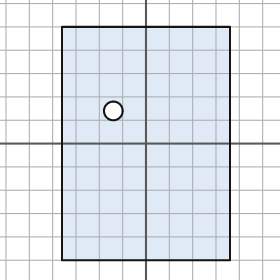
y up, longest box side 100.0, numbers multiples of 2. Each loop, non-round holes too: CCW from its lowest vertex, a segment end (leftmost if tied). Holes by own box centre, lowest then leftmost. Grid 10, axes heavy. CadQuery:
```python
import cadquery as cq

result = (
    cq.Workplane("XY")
    .moveTo(-36.0, -50.0)
    .lineTo(36.0, -50.0)
    .lineTo(36.0, 50.0)
    .lineTo(-36.0, 50.0)
    .close()
    .moveTo(-14.0, 14.0)
    .circle(4.0)
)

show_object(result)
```